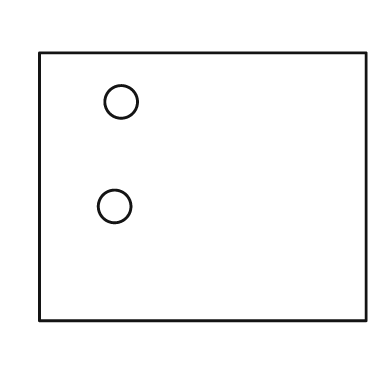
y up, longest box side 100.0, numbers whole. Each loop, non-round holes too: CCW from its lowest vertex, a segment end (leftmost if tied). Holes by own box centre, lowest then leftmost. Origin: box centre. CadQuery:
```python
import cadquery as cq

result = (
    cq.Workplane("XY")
    .moveTo(-50.0, -41.0)
    .lineTo(50.0, -41.0)
    .lineTo(50.0, 41.0)
    .lineTo(-50.0, 41.0)
    .close()
    .moveTo(-27.0, -6.0)
    .circle(5.0)
    .moveTo(-25.0, 26.0)
    .circle(5.0)
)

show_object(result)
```